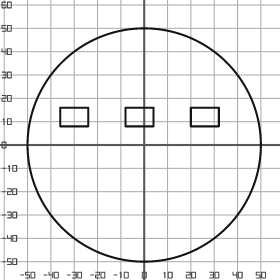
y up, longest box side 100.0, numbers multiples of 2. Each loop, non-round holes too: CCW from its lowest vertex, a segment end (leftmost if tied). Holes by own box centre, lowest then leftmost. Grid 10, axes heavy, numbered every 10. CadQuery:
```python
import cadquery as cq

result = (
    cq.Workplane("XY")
    .moveTo(0.0, 0.0)
    .circle(50.0)
    .moveTo(-36.0, 8.0)
    .lineTo(-24.0, 8.0)
    .lineTo(-24.0, 16.0)
    .lineTo(-36.0, 16.0)
    .close()
    .moveTo(-8.0, 8.0)
    .lineTo(4.0, 8.0)
    .lineTo(4.0, 16.0)
    .lineTo(-8.0, 16.0)
    .close()
    .moveTo(20.0, 8.0)
    .lineTo(32.0, 8.0)
    .lineTo(32.0, 16.0)
    .lineTo(20.0, 16.0)
    .close()
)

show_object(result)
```